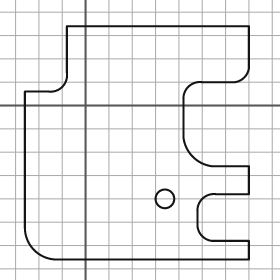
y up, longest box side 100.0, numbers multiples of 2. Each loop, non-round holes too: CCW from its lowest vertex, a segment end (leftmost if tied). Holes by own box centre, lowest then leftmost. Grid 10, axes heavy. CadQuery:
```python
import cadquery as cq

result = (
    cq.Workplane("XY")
    .moveTo(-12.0, -66.0)
    .lineTo(70.0, -66.0)
    .lineTo(70.0, -58.0)
    .lineTo(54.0, -58.0)
    .threePointArc((50.0, -56.0), (48.0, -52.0))
    .lineTo(48.0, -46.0)
    .threePointArc((50.0, -40.0), (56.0, -38.0))
    .lineTo(70.0, -38.0)
    .lineTo(70.0, -26.0)
    .lineTo(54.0, -26.0)
    .threePointArc((46.0, -22.0), (42.0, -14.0))
    .lineTo(42.0, 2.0)
    .threePointArc((44.0, 8.0), (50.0, 10.0))
    .lineTo(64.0, 10.0)
    .threePointArc((68.0, 12.0), (70.0, 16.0))
    .lineTo(70.0, 34.0)
    .lineTo(-8.0, 34.0)
    .lineTo(-8.0, 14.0)
    .threePointArc((-10.0, 8.0), (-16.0, 6.0))
    .lineTo(-26.0, 6.0)
    .lineTo(-26.0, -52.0)
    .threePointArc((-22.0, -62.0), (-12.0, -66.0))
    .close()
    .moveTo(34.0, -40.0)
    .circle(4.0)
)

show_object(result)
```